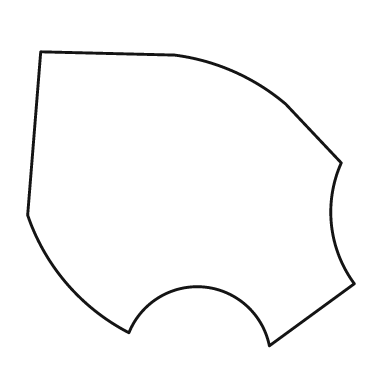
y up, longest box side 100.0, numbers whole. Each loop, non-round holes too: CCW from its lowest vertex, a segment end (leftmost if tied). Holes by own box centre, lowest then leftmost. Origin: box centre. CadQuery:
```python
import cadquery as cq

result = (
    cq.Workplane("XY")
    .moveTo(24.0, -45.0)
    .lineTo(50.0, -26.0)
    .threePointArc((43.0, -8.0), (46.0, 11.0))
    .lineTo(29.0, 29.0)
    .threePointArc((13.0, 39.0), (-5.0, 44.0))
    .lineTo(-46.0, 45.0)
    .lineTo(-50.0, -5.0)
    .threePointArc((-38.0, -26.0), (-19.0, -41.0))
    .threePointArc((4.0, -27.0), (24.0, -45.0))
    .close()
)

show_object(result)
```